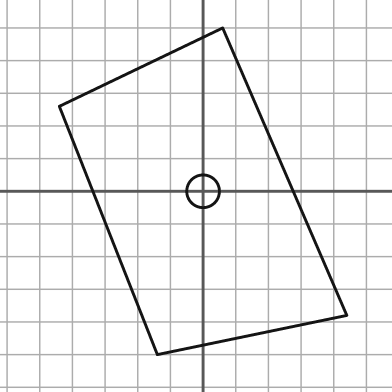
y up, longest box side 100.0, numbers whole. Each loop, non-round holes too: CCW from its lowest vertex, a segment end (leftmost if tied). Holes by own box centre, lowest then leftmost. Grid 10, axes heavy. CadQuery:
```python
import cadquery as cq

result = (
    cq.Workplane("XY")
    .moveTo(-14.0, -50.0)
    .lineTo(44.0, -38.0)
    .lineTo(6.0, 50.0)
    .lineTo(-44.0, 26.0)
    .close()
    .moveTo(0.0, 0.0)
    .circle(5.0)
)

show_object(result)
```